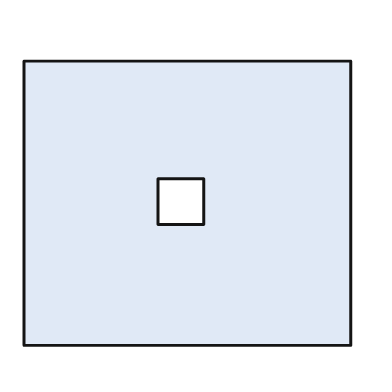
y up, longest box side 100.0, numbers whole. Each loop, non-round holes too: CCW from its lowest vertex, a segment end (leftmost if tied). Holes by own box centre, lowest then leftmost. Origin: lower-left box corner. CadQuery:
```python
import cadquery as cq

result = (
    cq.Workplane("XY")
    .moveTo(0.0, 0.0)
    .lineTo(100.0, 0.0)
    .lineTo(100.0, 87.0)
    .lineTo(0.0, 87.0)
    .close()
    .moveTo(41.0, 37.0)
    .lineTo(55.0, 37.0)
    .lineTo(55.0, 51.0)
    .lineTo(41.0, 51.0)
    .close()
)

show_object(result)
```